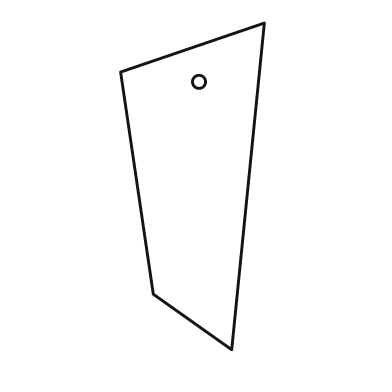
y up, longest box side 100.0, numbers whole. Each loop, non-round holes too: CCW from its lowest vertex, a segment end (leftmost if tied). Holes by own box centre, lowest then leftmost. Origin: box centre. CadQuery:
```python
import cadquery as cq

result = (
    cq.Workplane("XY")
    .moveTo(12.0, -50.0)
    .lineTo(22.0, 50.0)
    .lineTo(-22.0, 35.0)
    .lineTo(-12.0, -33.0)
    .close()
    .moveTo(2.0, 32.0)
    .circle(2.0)
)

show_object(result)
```